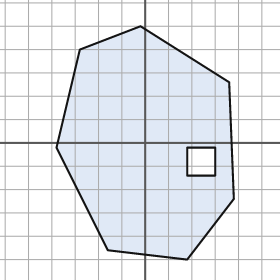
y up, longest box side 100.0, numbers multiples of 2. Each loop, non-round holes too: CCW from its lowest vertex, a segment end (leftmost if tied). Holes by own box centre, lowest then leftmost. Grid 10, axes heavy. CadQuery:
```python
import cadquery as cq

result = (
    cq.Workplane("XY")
    .moveTo(18.0, -50.0)
    .lineTo(38.0, -24.0)
    .lineTo(36.0, 26.0)
    .lineTo(-2.0, 50.0)
    .lineTo(-28.0, 40.0)
    .lineTo(-38.0, -2.0)
    .lineTo(-16.0, -46.0)
    .close()
    .moveTo(18.0, -14.0)
    .lineTo(30.0, -14.0)
    .lineTo(30.0, -2.0)
    .lineTo(18.0, -2.0)
    .close()
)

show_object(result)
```